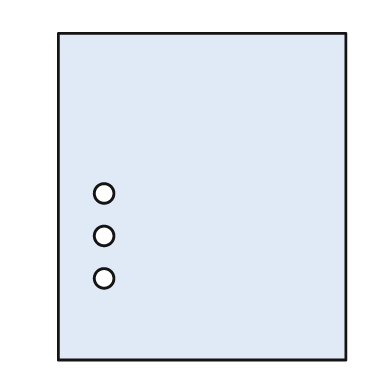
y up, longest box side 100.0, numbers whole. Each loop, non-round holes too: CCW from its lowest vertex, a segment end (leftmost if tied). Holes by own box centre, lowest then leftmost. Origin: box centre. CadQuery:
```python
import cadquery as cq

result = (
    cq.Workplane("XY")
    .moveTo(-44.0, -50.0)
    .lineTo(44.0, -50.0)
    .lineTo(44.0, 50.0)
    .lineTo(-44.0, 50.0)
    .close()
    .moveTo(-30.0, -25.0)
    .circle(3.0)
    .moveTo(-30.0, -12.0)
    .circle(3.0)
    .moveTo(-30.0, 1.0)
    .circle(3.0)
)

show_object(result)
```